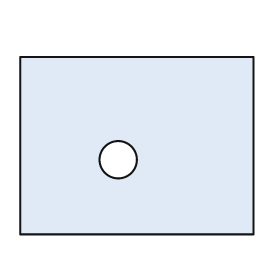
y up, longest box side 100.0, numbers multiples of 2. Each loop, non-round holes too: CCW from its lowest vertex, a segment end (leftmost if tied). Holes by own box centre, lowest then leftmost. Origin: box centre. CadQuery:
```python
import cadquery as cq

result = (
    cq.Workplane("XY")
    .moveTo(-50.0, -38.0)
    .lineTo(50.0, -38.0)
    .lineTo(50.0, 38.0)
    .lineTo(-50.0, 38.0)
    .close()
    .moveTo(-8.0, -6.0)
    .circle(8.0)
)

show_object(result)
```